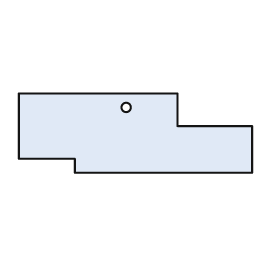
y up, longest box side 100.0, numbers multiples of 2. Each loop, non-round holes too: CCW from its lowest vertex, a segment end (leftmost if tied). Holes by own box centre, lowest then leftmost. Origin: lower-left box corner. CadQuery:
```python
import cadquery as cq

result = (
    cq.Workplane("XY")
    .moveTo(24.0, 0.0)
    .lineTo(100.0, 0.0)
    .lineTo(100.0, 20.0)
    .lineTo(68.0, 20.0)
    .lineTo(68.0, 34.0)
    .lineTo(0.0, 34.0)
    .lineTo(0.0, 6.0)
    .lineTo(24.0, 6.0)
    .close()
    .moveTo(46.0, 28.0)
    .circle(2.0)
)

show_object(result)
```